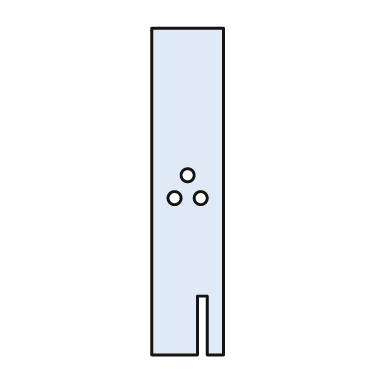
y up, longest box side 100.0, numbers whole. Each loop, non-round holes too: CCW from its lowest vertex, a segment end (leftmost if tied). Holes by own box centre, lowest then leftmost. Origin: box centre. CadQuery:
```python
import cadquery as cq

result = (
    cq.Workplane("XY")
    .moveTo(-11.0, -50.0)
    .lineTo(3.0, -50.0)
    .lineTo(3.0, -32.0)
    .lineTo(6.0, -32.0)
    .lineTo(6.0, -50.0)
    .lineTo(11.0, -50.0)
    .lineTo(11.0, 50.0)
    .lineTo(-11.0, 50.0)
    .close()
    .moveTo(-4.0, -2.0)
    .circle(2.0)
    .moveTo(4.0, -2.0)
    .circle(2.0)
    .moveTo(0.0, 5.0)
    .circle(2.0)
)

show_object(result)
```